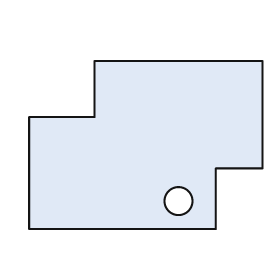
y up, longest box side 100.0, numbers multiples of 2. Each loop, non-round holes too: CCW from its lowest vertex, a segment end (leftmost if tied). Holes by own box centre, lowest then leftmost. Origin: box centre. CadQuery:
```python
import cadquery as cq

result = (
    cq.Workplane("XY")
    .moveTo(-50.0, -36.0)
    .lineTo(30.0, -36.0)
    .lineTo(30.0, -10.0)
    .lineTo(50.0, -10.0)
    .lineTo(50.0, 36.0)
    .lineTo(-22.0, 36.0)
    .lineTo(-22.0, 12.0)
    .lineTo(-50.0, 12.0)
    .close()
    .moveTo(14.0, -24.0)
    .circle(6.0)
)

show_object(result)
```